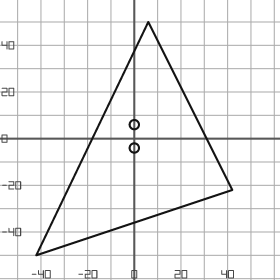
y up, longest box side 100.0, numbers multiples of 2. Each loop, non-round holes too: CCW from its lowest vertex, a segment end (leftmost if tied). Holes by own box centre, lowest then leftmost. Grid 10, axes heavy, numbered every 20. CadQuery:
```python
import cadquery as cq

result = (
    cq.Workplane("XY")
    .moveTo(-42.0, -50.0)
    .lineTo(42.0, -22.0)
    .lineTo(6.0, 50.0)
    .close()
    .moveTo(0.0, -4.0)
    .circle(2.0)
    .moveTo(0.0, 6.0)
    .circle(2.0)
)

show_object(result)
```